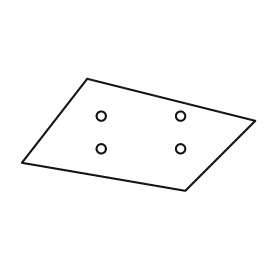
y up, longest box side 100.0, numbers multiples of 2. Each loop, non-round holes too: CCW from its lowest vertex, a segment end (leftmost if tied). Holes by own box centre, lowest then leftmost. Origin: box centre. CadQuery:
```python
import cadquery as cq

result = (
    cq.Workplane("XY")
    .moveTo(20.0, -24.0)
    .lineTo(50.0, 6.0)
    .lineTo(-22.0, 24.0)
    .lineTo(-50.0, -12.0)
    .close()
    .moveTo(-16.0, -6.0)
    .circle(2.0)
    .moveTo(18.0, -6.0)
    .circle(2.0)
    .moveTo(-16.0, 8.0)
    .circle(2.0)
    .moveTo(18.0, 8.0)
    .circle(2.0)
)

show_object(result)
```